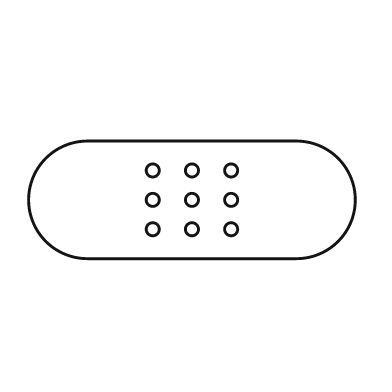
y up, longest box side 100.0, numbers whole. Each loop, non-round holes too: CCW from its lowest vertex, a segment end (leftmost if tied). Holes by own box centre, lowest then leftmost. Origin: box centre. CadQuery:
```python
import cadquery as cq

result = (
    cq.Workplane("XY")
    .moveTo(-32.0, -18.0)
    .lineTo(32.0, -18.0)
    .threePointArc((50.0, 0.0), (32.0, 18.0))
    .lineTo(-32.0, 18.0)
    .threePointArc((-50.0, 0.0), (-32.0, -18.0))
    .close()
    .moveTo(-12.0, -9.0)
    .circle(2.0)
    .moveTo(0.0, -9.0)
    .circle(2.0)
    .moveTo(12.0, -9.0)
    .circle(2.0)
    .moveTo(-12.0, 0.0)
    .circle(2.0)
    .moveTo(0.0, 0.0)
    .circle(2.0)
    .moveTo(12.0, 0.0)
    .circle(2.0)
    .moveTo(-12.0, 9.0)
    .circle(2.0)
    .moveTo(0.0, 9.0)
    .circle(2.0)
    .moveTo(12.0, 9.0)
    .circle(2.0)
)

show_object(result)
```